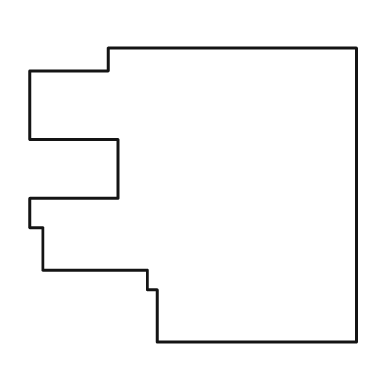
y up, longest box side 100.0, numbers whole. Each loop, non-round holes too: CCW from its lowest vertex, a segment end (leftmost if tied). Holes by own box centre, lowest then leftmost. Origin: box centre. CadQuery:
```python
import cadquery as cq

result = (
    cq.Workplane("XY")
    .moveTo(-11.0, -45.0)
    .lineTo(50.0, -45.0)
    .lineTo(50.0, 45.0)
    .lineTo(-26.0, 45.0)
    .lineTo(-26.0, 38.0)
    .lineTo(-50.0, 38.0)
    .lineTo(-50.0, 17.0)
    .lineTo(-23.0, 17.0)
    .lineTo(-23.0, -1.0)
    .lineTo(-50.0, -1.0)
    .lineTo(-50.0, -10.0)
    .lineTo(-46.0, -10.0)
    .lineTo(-46.0, -23.0)
    .lineTo(-14.0, -23.0)
    .lineTo(-14.0, -29.0)
    .lineTo(-11.0, -29.0)
    .close()
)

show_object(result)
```